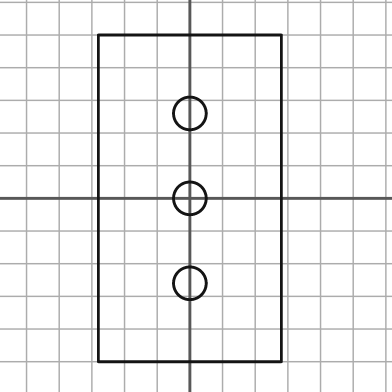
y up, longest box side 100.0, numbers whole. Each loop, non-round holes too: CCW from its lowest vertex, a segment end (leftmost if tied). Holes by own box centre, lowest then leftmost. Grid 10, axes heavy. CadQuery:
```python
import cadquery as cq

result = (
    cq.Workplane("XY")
    .moveTo(-28.0, -50.0)
    .lineTo(28.0, -50.0)
    .lineTo(28.0, 50.0)
    .lineTo(-28.0, 50.0)
    .close()
    .moveTo(0.0, -26.0)
    .circle(5.0)
    .moveTo(0.0, 0.0)
    .circle(5.0)
    .moveTo(0.0, 26.0)
    .circle(5.0)
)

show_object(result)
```